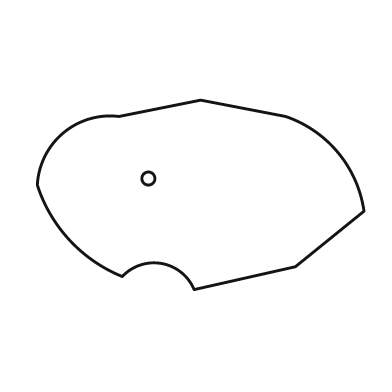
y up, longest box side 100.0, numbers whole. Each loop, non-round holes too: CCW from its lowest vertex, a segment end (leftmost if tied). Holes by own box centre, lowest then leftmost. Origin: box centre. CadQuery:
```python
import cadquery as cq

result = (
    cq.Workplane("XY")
    .moveTo(-2.0, -29.0)
    .lineTo(29.0, -22.0)
    .lineTo(50.0, -5.0)
    .threePointArc((42.0, 13.0), (26.0, 24.0))
    .lineTo(0.0, 29.0)
    .lineTo(-25.0, 24.0)
    .threePointArc((-42.0, 19.0), (-50.0, 3.0))
    .threePointArc((-40.0, -14.0), (-24.0, -25.0))
    .threePointArc((-12.0, -21.0), (-2.0, -29.0))
    .close()
    .moveTo(-16.0, 5.0)
    .circle(2.0)
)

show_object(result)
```